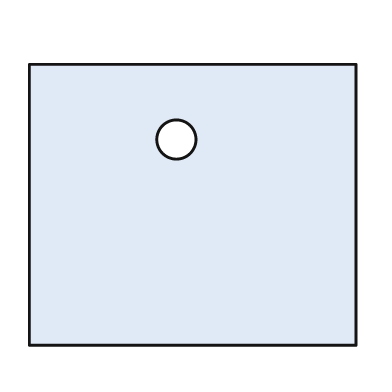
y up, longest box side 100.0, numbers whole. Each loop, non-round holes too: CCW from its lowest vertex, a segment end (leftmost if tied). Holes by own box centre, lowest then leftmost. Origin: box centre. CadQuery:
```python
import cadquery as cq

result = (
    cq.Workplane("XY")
    .moveTo(-50.0, -43.0)
    .lineTo(50.0, -43.0)
    .lineTo(50.0, 43.0)
    .lineTo(-50.0, 43.0)
    .close()
    .moveTo(-5.0, 20.0)
    .circle(6.0)
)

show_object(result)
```